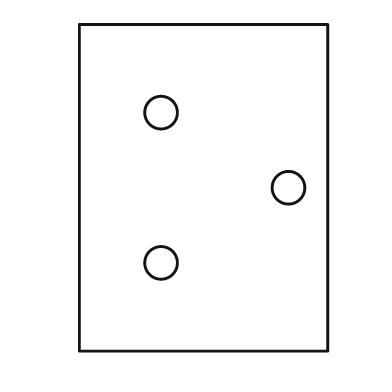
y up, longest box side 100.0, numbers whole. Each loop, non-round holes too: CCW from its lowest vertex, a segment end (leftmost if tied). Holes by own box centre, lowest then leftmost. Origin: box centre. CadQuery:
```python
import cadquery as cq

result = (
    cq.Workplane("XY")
    .moveTo(-38.0, -50.0)
    .lineTo(38.0, -50.0)
    .lineTo(38.0, 50.0)
    .lineTo(-38.0, 50.0)
    .close()
    .moveTo(-13.0, -23.0)
    .circle(5.0)
    .moveTo(26.0, 0.0)
    .circle(5.0)
    .moveTo(-13.0, 23.0)
    .circle(5.0)
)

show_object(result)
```